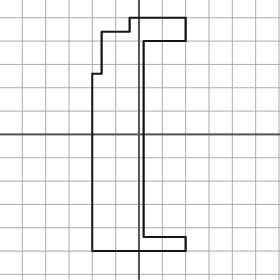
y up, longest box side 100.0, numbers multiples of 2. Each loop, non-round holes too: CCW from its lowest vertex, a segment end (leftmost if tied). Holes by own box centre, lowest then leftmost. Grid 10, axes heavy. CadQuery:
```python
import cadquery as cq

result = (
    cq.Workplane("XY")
    .moveTo(-20.0, -50.0)
    .lineTo(20.0, -50.0)
    .lineTo(20.0, -44.0)
    .lineTo(2.0, -44.0)
    .lineTo(2.0, 40.0)
    .lineTo(20.0, 40.0)
    .lineTo(20.0, 50.0)
    .lineTo(-4.0, 50.0)
    .lineTo(-4.0, 44.0)
    .lineTo(-16.0, 44.0)
    .lineTo(-16.0, 26.0)
    .lineTo(-20.0, 26.0)
    .close()
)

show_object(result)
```